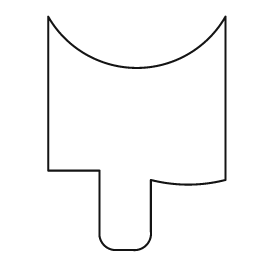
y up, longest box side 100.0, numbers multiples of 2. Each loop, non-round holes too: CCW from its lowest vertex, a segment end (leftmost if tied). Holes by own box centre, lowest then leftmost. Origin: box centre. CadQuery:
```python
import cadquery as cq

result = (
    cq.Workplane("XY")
    .moveTo(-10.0, -50.0)
    .lineTo(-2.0, -50.0)
    .threePointArc((4.0, -48.0), (6.0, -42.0))
    .lineTo(6.0, -20.0)
    .threePointArc((22.0, -22.0), (38.0, -20.0))
    .lineTo(38.0, 50.0)
    .threePointArc((0.0, 28.0), (-38.0, 50.0))
    .lineTo(-38.0, -16.0)
    .lineTo(-16.0, -16.0)
    .lineTo(-16.0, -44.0)
    .threePointArc((-14.0, -48.0), (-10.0, -50.0))
    .close()
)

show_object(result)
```